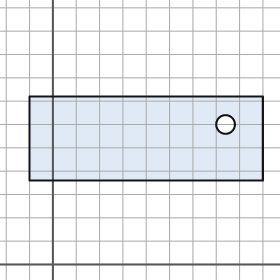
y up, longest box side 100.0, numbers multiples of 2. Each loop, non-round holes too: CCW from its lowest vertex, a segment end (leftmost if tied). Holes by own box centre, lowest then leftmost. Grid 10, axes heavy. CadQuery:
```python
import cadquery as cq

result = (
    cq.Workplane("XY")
    .moveTo(-10.0, 36.0)
    .lineTo(90.0, 36.0)
    .lineTo(90.0, 72.0)
    .lineTo(-10.0, 72.0)
    .close()
    .moveTo(74.0, 60.0)
    .circle(4.0)
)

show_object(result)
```